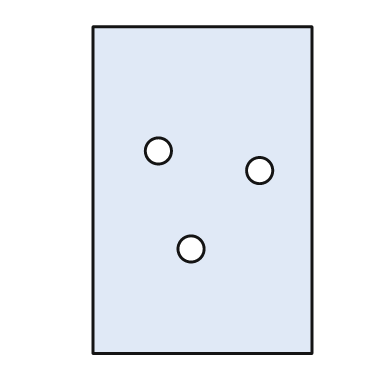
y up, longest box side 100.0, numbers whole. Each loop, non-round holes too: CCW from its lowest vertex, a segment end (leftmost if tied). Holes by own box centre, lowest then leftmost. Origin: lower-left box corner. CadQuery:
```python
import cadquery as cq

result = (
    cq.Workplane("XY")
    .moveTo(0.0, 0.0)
    .lineTo(67.0, 0.0)
    .lineTo(67.0, 100.0)
    .lineTo(0.0, 100.0)
    .close()
    .moveTo(30.0, 32.0)
    .circle(4.0)
    .moveTo(51.0, 56.0)
    .circle(4.0)
    .moveTo(20.0, 62.0)
    .circle(4.0)
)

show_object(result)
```